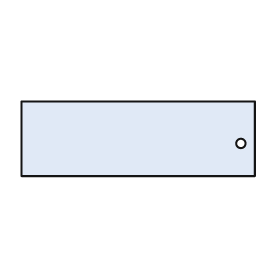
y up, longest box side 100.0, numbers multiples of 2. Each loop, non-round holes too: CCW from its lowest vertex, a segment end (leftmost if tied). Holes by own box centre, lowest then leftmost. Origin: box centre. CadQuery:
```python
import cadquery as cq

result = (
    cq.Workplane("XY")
    .moveTo(-50.0, -16.0)
    .lineTo(50.0, -16.0)
    .lineTo(50.0, 16.0)
    .lineTo(-50.0, 16.0)
    .close()
    .moveTo(44.0, -2.0)
    .circle(2.0)
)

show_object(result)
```